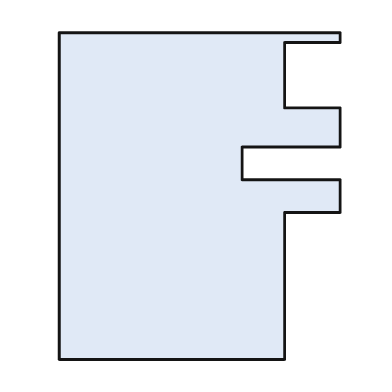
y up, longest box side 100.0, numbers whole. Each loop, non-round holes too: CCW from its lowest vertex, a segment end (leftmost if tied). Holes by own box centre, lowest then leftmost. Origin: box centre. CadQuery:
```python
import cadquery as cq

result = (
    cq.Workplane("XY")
    .moveTo(-43.0, -50.0)
    .lineTo(26.0, -50.0)
    .lineTo(26.0, -5.0)
    .lineTo(43.0, -5.0)
    .lineTo(43.0, 5.0)
    .lineTo(13.0, 5.0)
    .lineTo(13.0, 15.0)
    .lineTo(43.0, 15.0)
    .lineTo(43.0, 27.0)
    .lineTo(26.0, 27.0)
    .lineTo(26.0, 47.0)
    .lineTo(43.0, 47.0)
    .lineTo(43.0, 50.0)
    .lineTo(-43.0, 50.0)
    .close()
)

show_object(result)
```